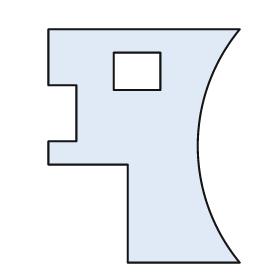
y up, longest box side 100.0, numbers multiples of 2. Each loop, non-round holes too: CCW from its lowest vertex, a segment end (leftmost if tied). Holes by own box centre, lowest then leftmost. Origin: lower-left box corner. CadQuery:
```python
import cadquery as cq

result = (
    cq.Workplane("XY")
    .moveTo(34.0, 0.0)
    .lineTo(82.0, 0.0)
    .threePointArc((64.0, 50.0), (82.0, 100.0))
    .lineTo(0.0, 100.0)
    .lineTo(0.0, 76.0)
    .lineTo(12.0, 76.0)
    .lineTo(12.0, 52.0)
    .lineTo(0.0, 52.0)
    .lineTo(0.0, 42.0)
    .lineTo(34.0, 42.0)
    .close()
    .moveTo(28.0, 74.0)
    .lineTo(48.0, 74.0)
    .lineTo(48.0, 90.0)
    .lineTo(28.0, 90.0)
    .close()
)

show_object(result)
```